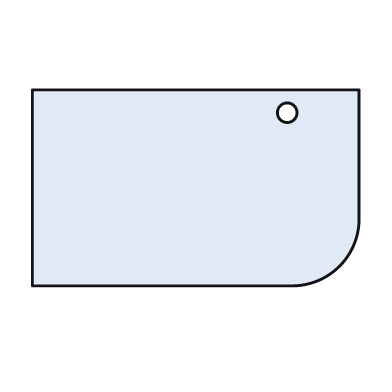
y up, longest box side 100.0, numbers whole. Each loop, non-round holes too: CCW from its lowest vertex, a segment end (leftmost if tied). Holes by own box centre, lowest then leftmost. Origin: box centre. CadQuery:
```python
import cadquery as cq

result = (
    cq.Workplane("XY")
    .moveTo(-50.0, -30.0)
    .lineTo(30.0, -30.0)
    .threePointArc((44.0, -24.0), (50.0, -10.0))
    .lineTo(50.0, 30.0)
    .lineTo(-50.0, 30.0)
    .close()
    .moveTo(28.0, 23.0)
    .circle(3.0)
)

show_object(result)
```